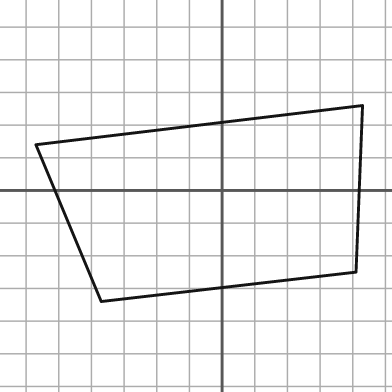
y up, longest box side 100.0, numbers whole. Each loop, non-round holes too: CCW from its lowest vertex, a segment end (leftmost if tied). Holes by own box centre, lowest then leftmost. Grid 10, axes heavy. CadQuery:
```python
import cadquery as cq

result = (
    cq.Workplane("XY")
    .moveTo(-37.0, -34.0)
    .lineTo(41.0, -25.0)
    .lineTo(43.0, 26.0)
    .lineTo(-57.0, 14.0)
    .close()
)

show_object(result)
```